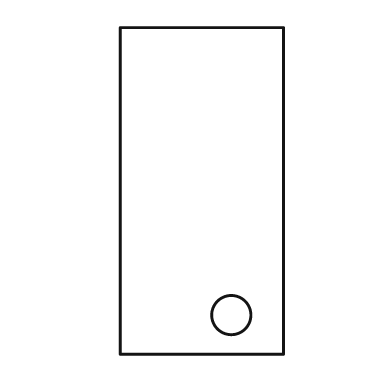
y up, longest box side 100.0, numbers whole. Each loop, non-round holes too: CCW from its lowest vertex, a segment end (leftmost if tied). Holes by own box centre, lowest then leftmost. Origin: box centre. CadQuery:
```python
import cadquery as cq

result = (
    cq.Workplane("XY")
    .moveTo(-25.0, -50.0)
    .lineTo(25.0, -50.0)
    .lineTo(25.0, 50.0)
    .lineTo(-25.0, 50.0)
    .close()
    .moveTo(9.0, -38.0)
    .circle(6.0)
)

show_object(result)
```